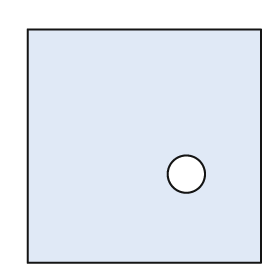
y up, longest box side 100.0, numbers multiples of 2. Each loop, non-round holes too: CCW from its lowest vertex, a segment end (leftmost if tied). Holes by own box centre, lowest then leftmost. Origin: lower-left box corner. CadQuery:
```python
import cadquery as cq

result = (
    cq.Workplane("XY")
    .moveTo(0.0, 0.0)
    .lineTo(100.0, 0.0)
    .lineTo(100.0, 100.0)
    .lineTo(0.0, 100.0)
    .close()
    .moveTo(68.0, 38.0)
    .circle(8.0)
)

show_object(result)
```